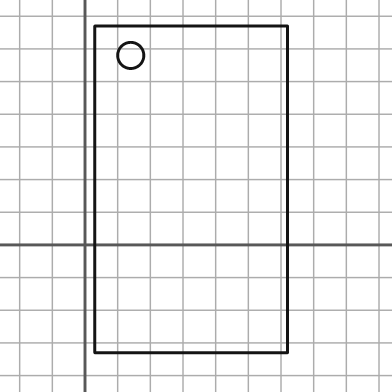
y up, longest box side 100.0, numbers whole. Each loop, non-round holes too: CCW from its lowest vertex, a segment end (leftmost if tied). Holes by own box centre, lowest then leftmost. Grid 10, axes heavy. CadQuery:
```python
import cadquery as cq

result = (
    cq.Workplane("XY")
    .moveTo(3.0, -33.0)
    .lineTo(62.0, -33.0)
    .lineTo(62.0, 67.0)
    .lineTo(3.0, 67.0)
    .close()
    .moveTo(14.0, 58.0)
    .circle(4.0)
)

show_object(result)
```